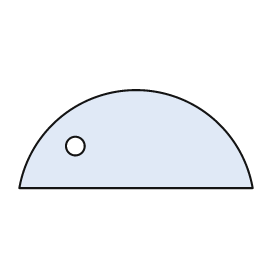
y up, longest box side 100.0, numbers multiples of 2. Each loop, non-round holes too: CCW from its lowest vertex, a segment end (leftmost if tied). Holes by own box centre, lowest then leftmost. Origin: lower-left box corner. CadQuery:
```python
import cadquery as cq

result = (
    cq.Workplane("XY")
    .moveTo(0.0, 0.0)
    .lineTo(100.0, 0.0)
    .threePointArc((50.0, 42.0), (0.0, 0.0))
    .close()
    .moveTo(24.0, 18.0)
    .circle(4.0)
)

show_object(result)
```